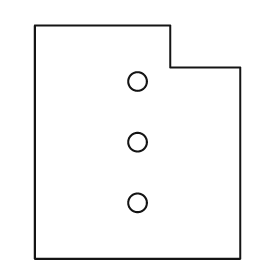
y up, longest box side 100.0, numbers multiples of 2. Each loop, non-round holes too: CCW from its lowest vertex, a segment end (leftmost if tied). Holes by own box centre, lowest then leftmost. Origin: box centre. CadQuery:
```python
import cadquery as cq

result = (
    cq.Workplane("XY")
    .moveTo(-44.0, -50.0)
    .lineTo(44.0, -50.0)
    .lineTo(44.0, 32.0)
    .lineTo(14.0, 32.0)
    .lineTo(14.0, 50.0)
    .lineTo(-44.0, 50.0)
    .close()
    .moveTo(0.0, -26.0)
    .circle(4.0)
    .moveTo(0.0, 0.0)
    .circle(4.0)
    .moveTo(0.0, 26.0)
    .circle(4.0)
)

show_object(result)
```